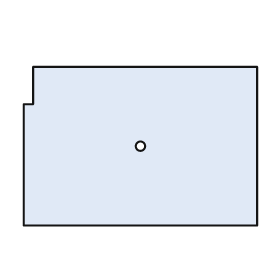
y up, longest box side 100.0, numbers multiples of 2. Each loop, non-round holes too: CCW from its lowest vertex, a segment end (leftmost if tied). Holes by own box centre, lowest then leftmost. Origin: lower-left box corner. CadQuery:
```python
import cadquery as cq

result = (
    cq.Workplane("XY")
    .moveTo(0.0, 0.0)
    .lineTo(100.0, 0.0)
    .lineTo(100.0, 68.0)
    .lineTo(4.0, 68.0)
    .lineTo(4.0, 52.0)
    .lineTo(0.0, 52.0)
    .close()
    .moveTo(50.0, 34.0)
    .circle(2.0)
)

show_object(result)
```